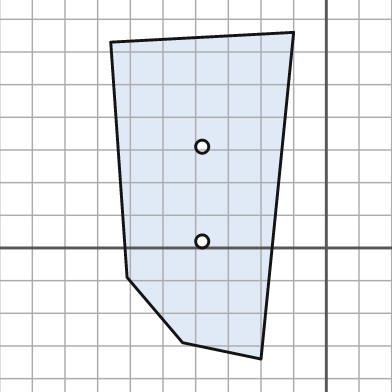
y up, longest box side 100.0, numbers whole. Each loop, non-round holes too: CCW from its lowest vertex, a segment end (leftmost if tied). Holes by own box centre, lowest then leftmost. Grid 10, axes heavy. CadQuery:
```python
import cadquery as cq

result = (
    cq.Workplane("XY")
    .moveTo(-20.0, -34.0)
    .lineTo(-10.0, 66.0)
    .lineTo(-66.0, 63.0)
    .lineTo(-61.0, -9.0)
    .lineTo(-44.0, -29.0)
    .close()
    .moveTo(-38.0, 2.0)
    .circle(2.0)
    .moveTo(-38.0, 31.0)
    .circle(2.0)
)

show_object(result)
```